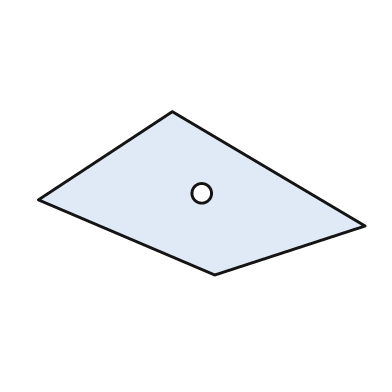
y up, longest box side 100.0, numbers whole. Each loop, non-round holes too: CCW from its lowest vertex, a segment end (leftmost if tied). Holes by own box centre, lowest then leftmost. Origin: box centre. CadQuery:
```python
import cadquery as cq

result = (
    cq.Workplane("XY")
    .moveTo(4.0, -25.0)
    .lineTo(50.0, -10.0)
    .lineTo(-9.0, 25.0)
    .lineTo(-50.0, -2.0)
    .close()
    .moveTo(0.0, 0.0)
    .circle(3.0)
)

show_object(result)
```